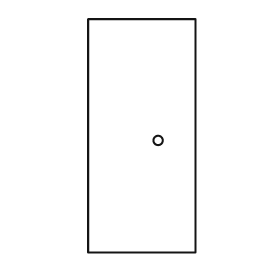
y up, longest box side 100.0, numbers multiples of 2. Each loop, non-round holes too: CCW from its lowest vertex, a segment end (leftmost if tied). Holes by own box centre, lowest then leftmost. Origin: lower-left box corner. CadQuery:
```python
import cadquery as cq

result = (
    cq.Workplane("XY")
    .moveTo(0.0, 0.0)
    .lineTo(46.0, 0.0)
    .lineTo(46.0, 100.0)
    .lineTo(0.0, 100.0)
    .close()
    .moveTo(30.0, 48.0)
    .circle(2.0)
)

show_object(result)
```